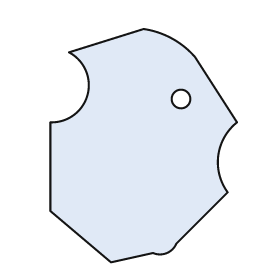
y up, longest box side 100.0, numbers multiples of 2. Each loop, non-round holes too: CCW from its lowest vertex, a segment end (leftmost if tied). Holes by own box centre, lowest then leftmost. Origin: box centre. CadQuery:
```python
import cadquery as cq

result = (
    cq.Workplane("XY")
    .moveTo(-14.0, -50.0)
    .lineTo(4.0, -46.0)
    .threePointArc((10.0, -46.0), (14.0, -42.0))
    .lineTo(36.0, -20.0)
    .threePointArc((32.0, -4.0), (40.0, 10.0))
    .lineTo(22.0, 38.0)
    .threePointArc((12.0, 46.0), (0.0, 50.0))
    .lineTo(-32.0, 40.0)
    .threePointArc((-24.0, 22.0), (-40.0, 10.0))
    .lineTo(-40.0, -28.0)
    .close()
    .moveTo(16.0, 20.0)
    .circle(4.0)
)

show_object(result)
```